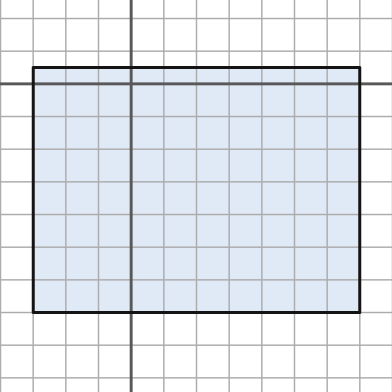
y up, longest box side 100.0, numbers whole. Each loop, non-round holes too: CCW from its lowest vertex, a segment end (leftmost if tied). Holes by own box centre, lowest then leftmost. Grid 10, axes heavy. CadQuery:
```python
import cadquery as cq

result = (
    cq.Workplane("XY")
    .moveTo(-30.0, -70.0)
    .lineTo(70.0, -70.0)
    .lineTo(70.0, 5.0)
    .lineTo(-30.0, 5.0)
    .close()
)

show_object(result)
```